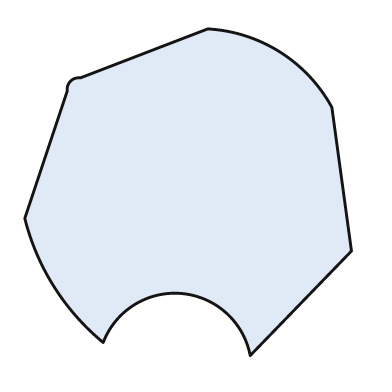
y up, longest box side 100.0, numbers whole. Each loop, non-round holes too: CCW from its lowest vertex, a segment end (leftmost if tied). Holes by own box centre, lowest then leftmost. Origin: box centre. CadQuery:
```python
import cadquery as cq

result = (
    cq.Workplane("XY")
    .moveTo(19.0, -50.0)
    .lineTo(50.0, -18.0)
    .lineTo(44.0, 26.0)
    .threePointArc((28.0, 43.0), (6.0, 50.0))
    .lineTo(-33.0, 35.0)
    .threePointArc((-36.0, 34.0), (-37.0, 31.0))
    .lineTo(-50.0, -8.0)
    .threePointArc((-41.0, -29.0), (-26.0, -46.0))
    .threePointArc((-2.0, -31.0), (19.0, -50.0))
    .close()
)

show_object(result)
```